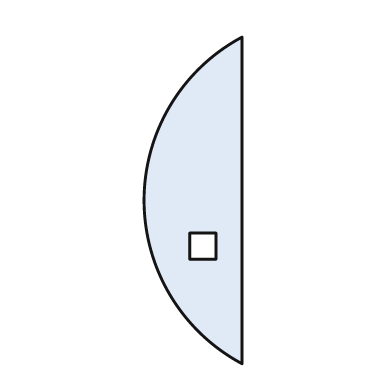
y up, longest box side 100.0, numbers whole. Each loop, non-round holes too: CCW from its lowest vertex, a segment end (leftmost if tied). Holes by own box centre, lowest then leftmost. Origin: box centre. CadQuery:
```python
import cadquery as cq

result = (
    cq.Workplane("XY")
    .moveTo(15.0, -50.0)
    .lineTo(15.0, 50.0)
    .threePointArc((-15.0, 0.0), (15.0, -50.0))
    .close()
    .moveTo(-1.0, -18.0)
    .lineTo(7.0, -18.0)
    .lineTo(7.0, -10.0)
    .lineTo(-1.0, -10.0)
    .close()
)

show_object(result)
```